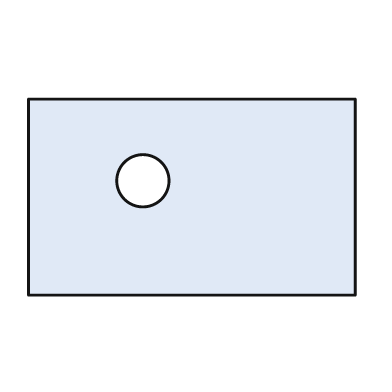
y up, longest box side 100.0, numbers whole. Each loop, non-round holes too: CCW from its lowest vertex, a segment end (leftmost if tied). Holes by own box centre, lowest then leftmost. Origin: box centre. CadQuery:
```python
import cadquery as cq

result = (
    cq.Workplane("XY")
    .moveTo(-50.0, -30.0)
    .lineTo(50.0, -30.0)
    .lineTo(50.0, 30.0)
    .lineTo(-50.0, 30.0)
    .close()
    .moveTo(-15.0, 5.0)
    .circle(8.0)
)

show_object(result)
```